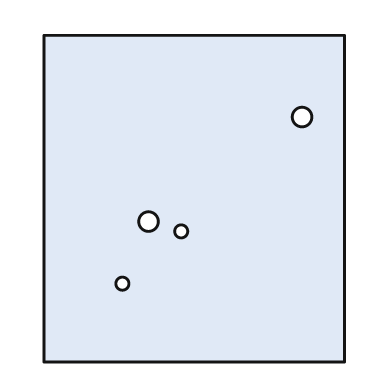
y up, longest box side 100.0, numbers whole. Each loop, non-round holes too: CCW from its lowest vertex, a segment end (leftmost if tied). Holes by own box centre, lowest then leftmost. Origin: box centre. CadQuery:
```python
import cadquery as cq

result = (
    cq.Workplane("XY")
    .moveTo(-46.0, -50.0)
    .lineTo(46.0, -50.0)
    .lineTo(46.0, 50.0)
    .lineTo(-46.0, 50.0)
    .close()
    .moveTo(-22.0, -26.0)
    .circle(2.0)
    .moveTo(-4.0, -10.0)
    .circle(2.0)
    .moveTo(-14.0, -7.0)
    .circle(3.0)
    .moveTo(33.0, 25.0)
    .circle(3.0)
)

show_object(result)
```